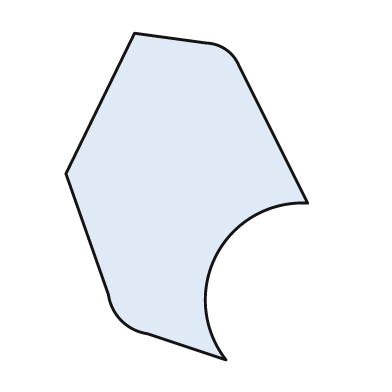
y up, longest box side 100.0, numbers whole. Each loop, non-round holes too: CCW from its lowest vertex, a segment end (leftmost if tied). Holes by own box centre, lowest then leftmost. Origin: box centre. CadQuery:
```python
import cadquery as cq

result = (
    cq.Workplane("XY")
    .moveTo(12.0, -50.0)
    .threePointArc((9.0, -18.0), (37.0, -2.0))
    .lineTo(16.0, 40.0)
    .threePointArc((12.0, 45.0), (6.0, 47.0))
    .lineTo(-16.0, 50.0)
    .lineTo(-37.0, 7.0)
    .lineTo(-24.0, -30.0)
    .threePointArc((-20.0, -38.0), (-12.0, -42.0))
    .close()
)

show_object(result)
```